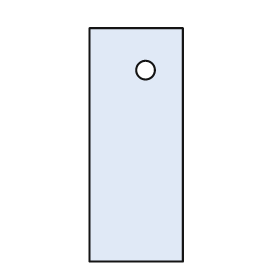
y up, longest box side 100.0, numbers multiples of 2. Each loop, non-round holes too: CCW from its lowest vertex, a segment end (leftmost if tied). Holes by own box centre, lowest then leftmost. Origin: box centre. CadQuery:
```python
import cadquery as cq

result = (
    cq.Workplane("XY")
    .moveTo(-20.0, -50.0)
    .lineTo(20.0, -50.0)
    .lineTo(20.0, 50.0)
    .lineTo(-20.0, 50.0)
    .close()
    .moveTo(4.0, 32.0)
    .circle(4.0)
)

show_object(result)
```